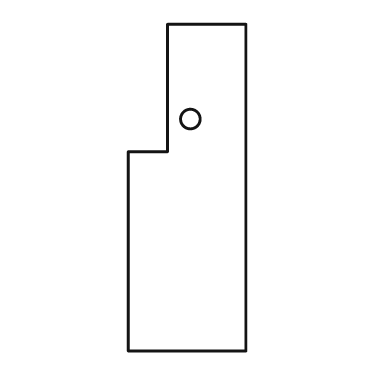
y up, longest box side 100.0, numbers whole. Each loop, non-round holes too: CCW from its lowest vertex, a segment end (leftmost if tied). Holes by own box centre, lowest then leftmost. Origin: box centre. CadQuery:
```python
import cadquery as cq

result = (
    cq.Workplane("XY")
    .moveTo(-18.0, -50.0)
    .lineTo(18.0, -50.0)
    .lineTo(18.0, 50.0)
    .lineTo(-6.0, 50.0)
    .lineTo(-6.0, 11.0)
    .lineTo(-18.0, 11.0)
    .close()
    .moveTo(1.0, 21.0)
    .circle(3.0)
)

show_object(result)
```